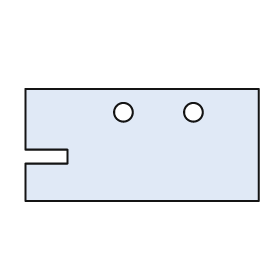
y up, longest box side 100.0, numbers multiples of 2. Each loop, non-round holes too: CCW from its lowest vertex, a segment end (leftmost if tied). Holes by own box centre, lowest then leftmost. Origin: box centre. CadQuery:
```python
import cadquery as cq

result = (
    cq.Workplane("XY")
    .moveTo(-50.0, -24.0)
    .lineTo(50.0, -24.0)
    .lineTo(50.0, 24.0)
    .lineTo(-50.0, 24.0)
    .lineTo(-50.0, -2.0)
    .lineTo(-32.0, -2.0)
    .lineTo(-32.0, -8.0)
    .lineTo(-50.0, -8.0)
    .close()
    .moveTo(-8.0, 14.0)
    .circle(4.0)
    .moveTo(22.0, 14.0)
    .circle(4.0)
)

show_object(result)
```